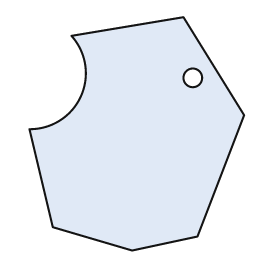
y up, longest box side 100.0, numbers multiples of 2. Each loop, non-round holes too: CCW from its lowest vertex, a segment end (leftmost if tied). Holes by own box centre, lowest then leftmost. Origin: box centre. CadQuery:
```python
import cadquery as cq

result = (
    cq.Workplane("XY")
    .moveTo(-2.0, -50.0)
    .lineTo(26.0, -44.0)
    .lineTo(46.0, 8.0)
    .lineTo(20.0, 50.0)
    .lineTo(-28.0, 42.0)
    .threePointArc((-24.0, 16.0), (-46.0, 2.0))
    .lineTo(-36.0, -40.0)
    .close()
    .moveTo(24.0, 24.0)
    .circle(4.0)
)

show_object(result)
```